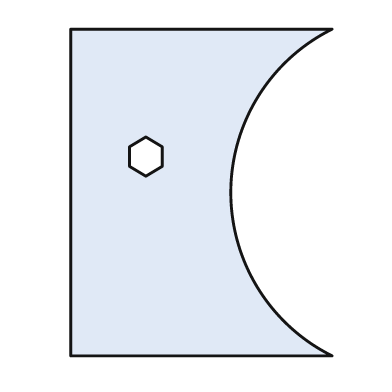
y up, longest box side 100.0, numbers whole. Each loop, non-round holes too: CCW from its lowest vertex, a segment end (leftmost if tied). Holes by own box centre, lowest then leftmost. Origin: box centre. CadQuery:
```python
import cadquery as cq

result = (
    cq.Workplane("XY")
    .moveTo(-40.0, -50.0)
    .lineTo(40.0, -50.0)
    .threePointArc((9.0, 0.0), (40.0, 50.0))
    .lineTo(-40.0, 50.0)
    .close()
    .moveTo(-17.0, 5.0)
    .lineTo(-12.0, 8.0)
    .lineTo(-12.0, 14.0)
    .lineTo(-17.0, 17.0)
    .lineTo(-22.0, 14.0)
    .lineTo(-22.0, 8.0)
    .close()
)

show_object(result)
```